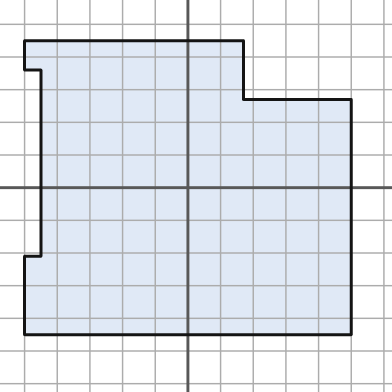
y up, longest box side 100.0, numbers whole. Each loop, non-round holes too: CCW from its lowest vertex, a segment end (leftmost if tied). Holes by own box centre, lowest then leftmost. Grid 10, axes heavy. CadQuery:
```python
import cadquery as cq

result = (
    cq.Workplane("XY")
    .moveTo(-50.0, -45.0)
    .lineTo(50.0, -45.0)
    .lineTo(50.0, 27.0)
    .lineTo(17.0, 27.0)
    .lineTo(17.0, 45.0)
    .lineTo(-50.0, 45.0)
    .lineTo(-50.0, 36.0)
    .lineTo(-45.0, 36.0)
    .lineTo(-45.0, -21.0)
    .lineTo(-50.0, -21.0)
    .close()
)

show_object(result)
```